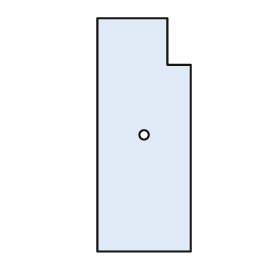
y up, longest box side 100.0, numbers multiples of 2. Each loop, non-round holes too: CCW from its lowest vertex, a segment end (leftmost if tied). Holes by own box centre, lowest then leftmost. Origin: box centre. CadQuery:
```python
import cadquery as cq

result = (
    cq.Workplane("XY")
    .moveTo(-20.0, -50.0)
    .lineTo(20.0, -50.0)
    .lineTo(20.0, 30.0)
    .lineTo(10.0, 30.0)
    .lineTo(10.0, 50.0)
    .lineTo(-20.0, 50.0)
    .close()
    .moveTo(0.0, 0.0)
    .circle(2.0)
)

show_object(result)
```